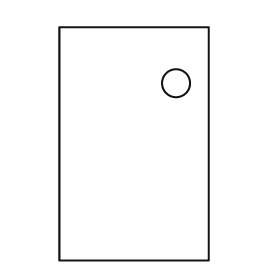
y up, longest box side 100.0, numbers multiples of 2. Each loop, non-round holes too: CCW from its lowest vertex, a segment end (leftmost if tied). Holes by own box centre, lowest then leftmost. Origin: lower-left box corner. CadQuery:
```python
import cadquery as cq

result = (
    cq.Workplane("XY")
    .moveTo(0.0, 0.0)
    .lineTo(64.0, 0.0)
    .lineTo(64.0, 100.0)
    .lineTo(0.0, 100.0)
    .close()
    .moveTo(50.0, 76.0)
    .circle(6.0)
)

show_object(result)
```